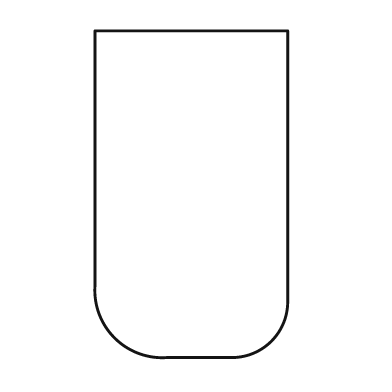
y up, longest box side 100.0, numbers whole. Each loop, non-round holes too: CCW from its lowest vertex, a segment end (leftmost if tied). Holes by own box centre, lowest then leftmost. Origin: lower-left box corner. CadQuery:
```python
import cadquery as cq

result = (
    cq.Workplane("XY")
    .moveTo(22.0, 0.0)
    .lineTo(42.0, 0.0)
    .threePointArc((54.0, 5.0), (59.0, 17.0))
    .lineTo(59.0, 100.0)
    .lineTo(0.0, 100.0)
    .lineTo(0.0, 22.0)
    .threePointArc((6.0, 6.0), (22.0, 0.0))
    .close()
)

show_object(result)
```